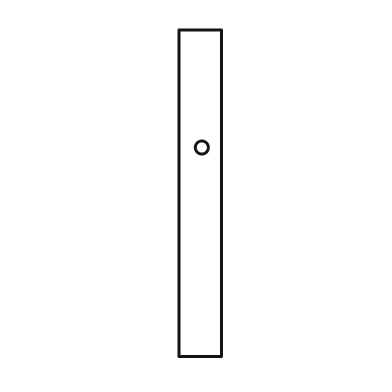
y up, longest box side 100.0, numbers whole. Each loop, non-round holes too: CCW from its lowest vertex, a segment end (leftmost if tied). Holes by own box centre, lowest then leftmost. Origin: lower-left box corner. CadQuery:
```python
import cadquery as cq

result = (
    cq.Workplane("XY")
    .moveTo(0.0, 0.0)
    .lineTo(13.0, 0.0)
    .lineTo(13.0, 100.0)
    .lineTo(0.0, 100.0)
    .close()
    .moveTo(7.0, 64.0)
    .circle(2.0)
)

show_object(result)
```